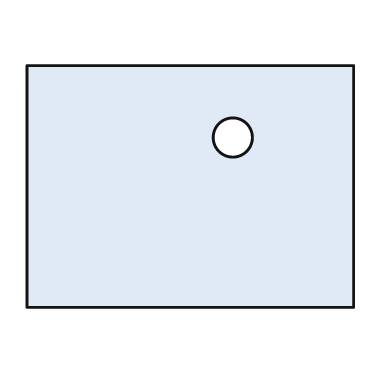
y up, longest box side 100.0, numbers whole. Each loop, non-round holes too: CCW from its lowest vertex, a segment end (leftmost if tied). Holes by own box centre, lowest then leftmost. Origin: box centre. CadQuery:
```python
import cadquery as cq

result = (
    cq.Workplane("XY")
    .moveTo(-50.0, -37.0)
    .lineTo(50.0, -37.0)
    .lineTo(50.0, 37.0)
    .lineTo(-50.0, 37.0)
    .close()
    .moveTo(13.0, 15.0)
    .circle(6.0)
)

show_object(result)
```